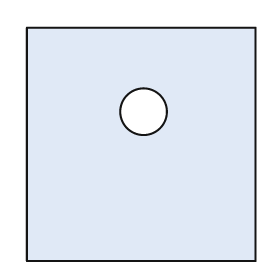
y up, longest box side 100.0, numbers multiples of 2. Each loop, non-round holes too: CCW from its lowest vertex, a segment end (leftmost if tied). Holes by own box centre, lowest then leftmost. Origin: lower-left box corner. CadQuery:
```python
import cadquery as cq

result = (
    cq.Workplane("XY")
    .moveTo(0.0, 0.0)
    .lineTo(98.0, 0.0)
    .lineTo(98.0, 100.0)
    .lineTo(0.0, 100.0)
    .close()
    .moveTo(50.0, 64.0)
    .circle(10.0)
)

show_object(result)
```